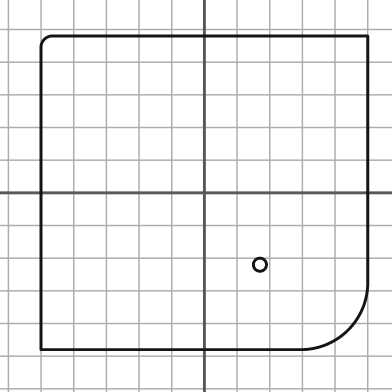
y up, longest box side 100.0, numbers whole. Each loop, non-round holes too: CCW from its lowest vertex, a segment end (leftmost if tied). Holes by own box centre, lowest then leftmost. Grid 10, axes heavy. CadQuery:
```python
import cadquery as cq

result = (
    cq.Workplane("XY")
    .moveTo(-50.0, -48.0)
    .lineTo(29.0, -48.0)
    .threePointArc((44.0, -42.0), (50.0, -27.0))
    .lineTo(50.0, 48.0)
    .lineTo(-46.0, 48.0)
    .threePointArc((-49.0, 47.0), (-50.0, 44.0))
    .close()
    .moveTo(17.0, -22.0)
    .circle(2.0)
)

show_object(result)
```